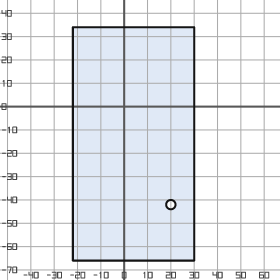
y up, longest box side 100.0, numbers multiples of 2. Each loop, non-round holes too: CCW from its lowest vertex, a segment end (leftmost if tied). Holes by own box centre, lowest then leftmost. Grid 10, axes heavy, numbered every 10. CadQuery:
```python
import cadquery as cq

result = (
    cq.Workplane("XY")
    .moveTo(-22.0, -66.0)
    .lineTo(30.0, -66.0)
    .lineTo(30.0, 34.0)
    .lineTo(-22.0, 34.0)
    .close()
    .moveTo(20.0, -42.0)
    .circle(2.0)
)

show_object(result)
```